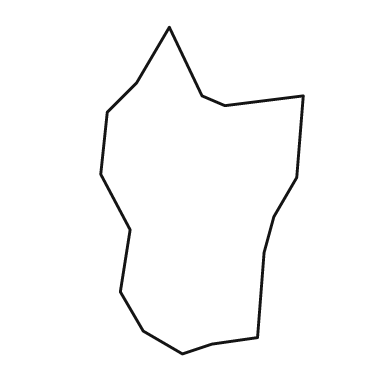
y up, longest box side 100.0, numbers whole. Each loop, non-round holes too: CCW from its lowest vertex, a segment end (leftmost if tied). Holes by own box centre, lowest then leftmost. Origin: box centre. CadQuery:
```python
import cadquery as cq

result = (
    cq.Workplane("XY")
    .moveTo(-6.0, -50.0)
    .lineTo(3.0, -47.0)
    .lineTo(17.0, -45.0)
    .lineTo(19.0, -19.0)
    .lineTo(22.0, -8.0)
    .lineTo(29.0, 4.0)
    .lineTo(31.0, 29.0)
    .lineTo(7.0, 26.0)
    .lineTo(0.0, 29.0)
    .lineTo(-10.0, 50.0)
    .lineTo(-20.0, 33.0)
    .lineTo(-29.0, 24.0)
    .lineTo(-31.0, 5.0)
    .lineTo(-22.0, -12.0)
    .lineTo(-25.0, -31.0)
    .lineTo(-18.0, -43.0)
    .close()
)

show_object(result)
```